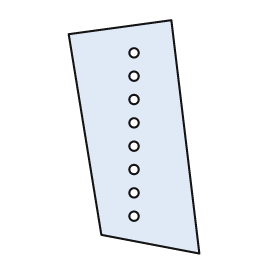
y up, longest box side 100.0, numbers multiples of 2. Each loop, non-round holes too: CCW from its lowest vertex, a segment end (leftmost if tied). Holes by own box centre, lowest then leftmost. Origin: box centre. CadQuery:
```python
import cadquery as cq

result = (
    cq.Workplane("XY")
    .moveTo(28.0, -50.0)
    .lineTo(16.0, 50.0)
    .lineTo(-28.0, 44.0)
    .lineTo(-14.0, -42.0)
    .close()
    .moveTo(0.0, -34.0)
    .circle(2.0)
    .moveTo(0.0, -24.0)
    .circle(2.0)
    .moveTo(0.0, -14.0)
    .circle(2.0)
    .moveTo(0.0, -4.0)
    .circle(2.0)
    .moveTo(0.0, 6.0)
    .circle(2.0)
    .moveTo(0.0, 16.0)
    .circle(2.0)
    .moveTo(0.0, 26.0)
    .circle(2.0)
    .moveTo(0.0, 36.0)
    .circle(2.0)
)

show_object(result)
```